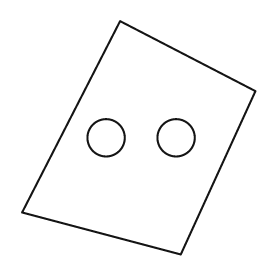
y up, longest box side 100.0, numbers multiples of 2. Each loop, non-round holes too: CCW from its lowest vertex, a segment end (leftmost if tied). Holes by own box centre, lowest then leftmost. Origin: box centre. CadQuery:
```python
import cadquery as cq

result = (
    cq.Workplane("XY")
    .moveTo(18.0, -50.0)
    .lineTo(50.0, 20.0)
    .lineTo(-8.0, 50.0)
    .lineTo(-50.0, -32.0)
    .close()
    .moveTo(-14.0, 0.0)
    .circle(8.0)
    .moveTo(16.0, 0.0)
    .circle(8.0)
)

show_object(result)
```